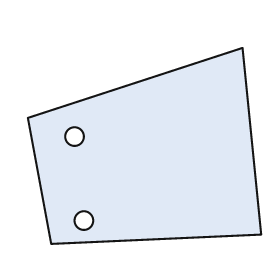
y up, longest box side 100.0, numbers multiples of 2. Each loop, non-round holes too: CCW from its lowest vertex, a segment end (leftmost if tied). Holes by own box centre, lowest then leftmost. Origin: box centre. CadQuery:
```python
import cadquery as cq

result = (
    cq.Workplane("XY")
    .moveTo(-40.0, -42.0)
    .lineTo(50.0, -38.0)
    .lineTo(42.0, 42.0)
    .lineTo(-50.0, 12.0)
    .close()
    .moveTo(-26.0, -32.0)
    .circle(4.0)
    .moveTo(-30.0, 4.0)
    .circle(4.0)
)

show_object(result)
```